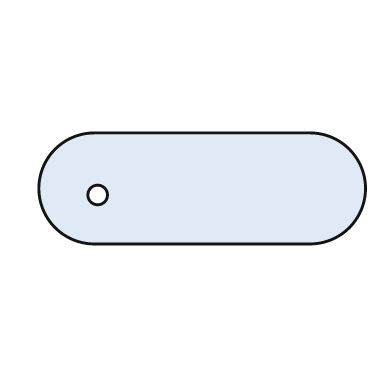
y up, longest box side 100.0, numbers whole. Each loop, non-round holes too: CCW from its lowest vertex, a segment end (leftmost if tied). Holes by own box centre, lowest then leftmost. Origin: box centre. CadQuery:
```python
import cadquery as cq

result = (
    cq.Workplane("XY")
    .moveTo(-33.0, -17.0)
    .lineTo(33.0, -17.0)
    .threePointArc((50.0, 0.0), (33.0, 17.0))
    .lineTo(-33.0, 17.0)
    .threePointArc((-50.0, 0.0), (-33.0, -17.0))
    .close()
    .moveTo(-32.0, -2.0)
    .circle(3.0)
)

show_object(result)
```